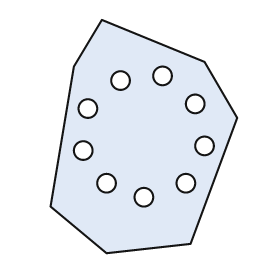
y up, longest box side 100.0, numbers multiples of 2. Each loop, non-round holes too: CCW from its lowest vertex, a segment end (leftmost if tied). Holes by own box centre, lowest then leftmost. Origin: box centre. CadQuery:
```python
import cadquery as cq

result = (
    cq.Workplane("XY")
    .moveTo(-16.0, -50.0)
    .lineTo(20.0, -46.0)
    .lineTo(40.0, 8.0)
    .lineTo(26.0, 32.0)
    .lineTo(-18.0, 50.0)
    .lineTo(-30.0, 30.0)
    .lineTo(-40.0, -30.0)
    .close()
    .moveTo(0.0, -26.0)
    .circle(4.0)
    .moveTo(-16.0, -20.0)
    .circle(4.0)
    .moveTo(18.0, -20.0)
    .circle(4.0)
    .moveTo(-26.0, -6.0)
    .circle(4.0)
    .moveTo(26.0, -4.0)
    .circle(4.0)
    .moveTo(-24.0, 12.0)
    .circle(4.0)
    .moveTo(22.0, 14.0)
    .circle(4.0)
    .moveTo(-10.0, 24.0)
    .circle(4.0)
    .moveTo(8.0, 26.0)
    .circle(4.0)
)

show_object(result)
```